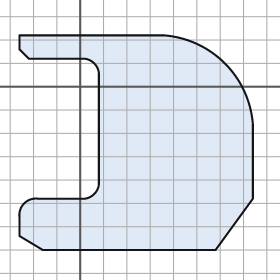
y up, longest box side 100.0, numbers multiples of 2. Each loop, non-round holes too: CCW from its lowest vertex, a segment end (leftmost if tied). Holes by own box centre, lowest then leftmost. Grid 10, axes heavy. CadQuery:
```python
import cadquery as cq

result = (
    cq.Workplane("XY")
    .moveTo(-16.0, -70.0)
    .lineTo(58.0, -70.0)
    .lineTo(74.0, -48.0)
    .lineTo(74.0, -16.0)
    .threePointArc((62.0, 10.0), (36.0, 22.0))
    .lineTo(-26.0, 22.0)
    .lineTo(-26.0, 16.0)
    .lineTo(-22.0, 12.0)
    .lineTo(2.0, 12.0)
    .threePointArc((6.0, 10.0), (8.0, 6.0))
    .lineTo(8.0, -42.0)
    .threePointArc((6.0, -46.0), (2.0, -48.0))
    .lineTo(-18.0, -48.0)
    .threePointArc((-24.0, -50.0), (-26.0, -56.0))
    .lineTo(-26.0, -64.0)
    .close()
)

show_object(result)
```